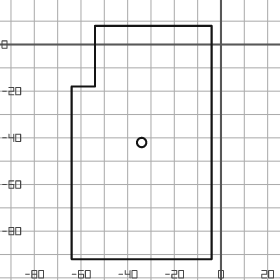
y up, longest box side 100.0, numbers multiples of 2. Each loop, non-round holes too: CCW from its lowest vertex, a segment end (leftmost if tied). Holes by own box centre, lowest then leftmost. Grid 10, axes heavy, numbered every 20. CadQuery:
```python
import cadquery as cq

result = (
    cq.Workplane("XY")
    .moveTo(-64.0, -92.0)
    .lineTo(-4.0, -92.0)
    .lineTo(-4.0, 8.0)
    .lineTo(-54.0, 8.0)
    .lineTo(-54.0, -18.0)
    .lineTo(-64.0, -18.0)
    .close()
    .moveTo(-34.0, -42.0)
    .circle(2.0)
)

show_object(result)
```